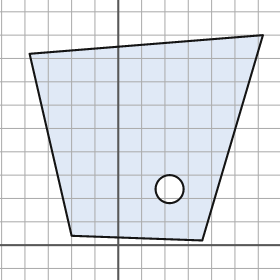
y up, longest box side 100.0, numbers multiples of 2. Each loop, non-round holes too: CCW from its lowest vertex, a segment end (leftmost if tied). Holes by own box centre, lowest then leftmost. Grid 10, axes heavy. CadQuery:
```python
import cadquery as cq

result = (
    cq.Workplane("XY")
    .moveTo(36.0, 2.0)
    .lineTo(62.0, 90.0)
    .lineTo(-38.0, 82.0)
    .lineTo(-20.0, 4.0)
    .close()
    .moveTo(22.0, 24.0)
    .circle(6.0)
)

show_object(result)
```